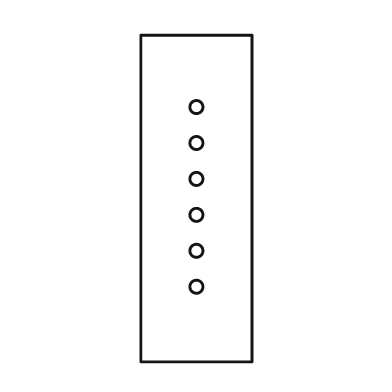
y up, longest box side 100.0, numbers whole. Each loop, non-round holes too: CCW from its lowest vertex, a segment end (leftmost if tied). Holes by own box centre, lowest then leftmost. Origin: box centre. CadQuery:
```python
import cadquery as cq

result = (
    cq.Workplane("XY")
    .moveTo(-17.0, -50.0)
    .lineTo(17.0, -50.0)
    .lineTo(17.0, 50.0)
    .lineTo(-17.0, 50.0)
    .close()
    .moveTo(0.0, -27.0)
    .circle(2.0)
    .moveTo(0.0, -16.0)
    .circle(2.0)
    .moveTo(0.0, -5.0)
    .circle(2.0)
    .moveTo(0.0, 6.0)
    .circle(2.0)
    .moveTo(0.0, 17.0)
    .circle(2.0)
    .moveTo(0.0, 28.0)
    .circle(2.0)
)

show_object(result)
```